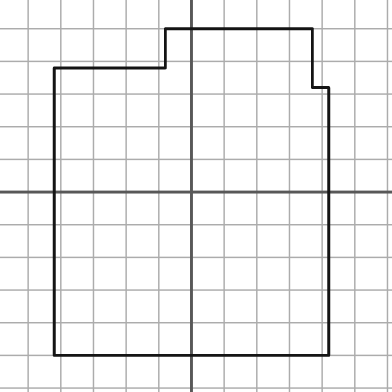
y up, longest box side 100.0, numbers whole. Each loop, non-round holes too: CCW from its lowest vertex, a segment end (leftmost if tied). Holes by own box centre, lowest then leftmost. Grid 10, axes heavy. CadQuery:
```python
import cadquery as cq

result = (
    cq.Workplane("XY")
    .moveTo(-42.0, -50.0)
    .lineTo(42.0, -50.0)
    .lineTo(42.0, 32.0)
    .lineTo(37.0, 32.0)
    .lineTo(37.0, 50.0)
    .lineTo(-8.0, 50.0)
    .lineTo(-8.0, 38.0)
    .lineTo(-42.0, 38.0)
    .close()
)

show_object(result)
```